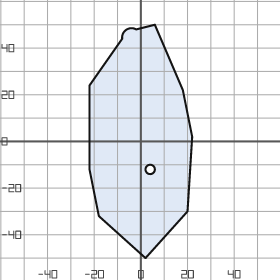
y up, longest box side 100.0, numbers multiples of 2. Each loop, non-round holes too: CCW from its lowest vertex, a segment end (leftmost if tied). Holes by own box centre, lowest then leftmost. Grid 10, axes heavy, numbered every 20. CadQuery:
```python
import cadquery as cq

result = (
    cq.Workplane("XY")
    .moveTo(2.0, -50.0)
    .lineTo(20.0, -30.0)
    .lineTo(22.0, 2.0)
    .lineTo(18.0, 22.0)
    .lineTo(6.0, 50.0)
    .lineTo(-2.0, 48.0)
    .threePointArc((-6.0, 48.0), (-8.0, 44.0))
    .lineTo(-22.0, 24.0)
    .lineTo(-22.0, -12.0)
    .lineTo(-18.0, -32.0)
    .close()
    .moveTo(4.0, -12.0)
    .circle(2.0)
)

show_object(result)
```